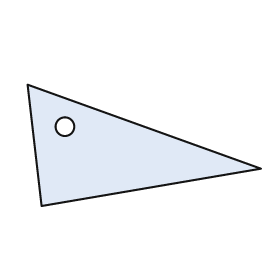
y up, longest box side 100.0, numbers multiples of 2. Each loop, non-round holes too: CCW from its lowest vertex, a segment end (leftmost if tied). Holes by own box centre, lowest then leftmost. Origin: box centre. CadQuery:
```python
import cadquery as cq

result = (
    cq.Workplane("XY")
    .moveTo(-44.0, -26.0)
    .lineTo(50.0, -10.0)
    .lineTo(-50.0, 26.0)
    .close()
    .moveTo(-34.0, 8.0)
    .circle(4.0)
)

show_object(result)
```